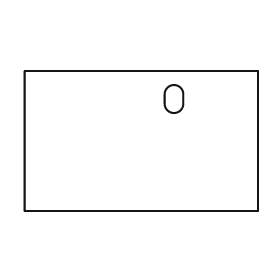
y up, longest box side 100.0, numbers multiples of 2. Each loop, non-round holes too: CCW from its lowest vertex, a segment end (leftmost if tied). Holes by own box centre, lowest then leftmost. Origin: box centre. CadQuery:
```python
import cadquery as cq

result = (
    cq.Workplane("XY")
    .moveTo(-50.0, -30.0)
    .lineTo(50.0, -30.0)
    .lineTo(50.0, 30.0)
    .lineTo(-50.0, 30.0)
    .close()
    .moveTo(10.0, 16.0)
    .threePointArc((14.0, 12.0), (18.0, 16.0))
    .lineTo(18.0, 20.0)
    .threePointArc((14.0, 24.0), (10.0, 20.0))
    .close()
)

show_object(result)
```